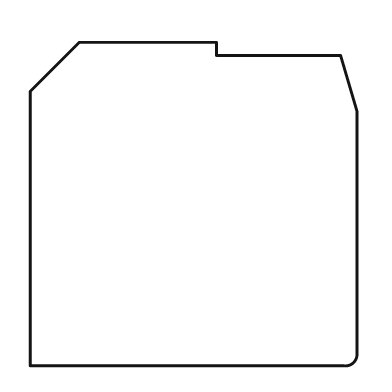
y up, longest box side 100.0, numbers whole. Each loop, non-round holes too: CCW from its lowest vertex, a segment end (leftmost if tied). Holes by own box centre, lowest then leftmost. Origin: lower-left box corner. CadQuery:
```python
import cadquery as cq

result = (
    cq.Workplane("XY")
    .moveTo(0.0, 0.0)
    .lineTo(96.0, 0.0)
    .threePointArc((99.0, 1.0), (100.0, 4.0))
    .lineTo(100.0, 78.0)
    .lineTo(95.0, 95.0)
    .lineTo(57.0, 95.0)
    .lineTo(57.0, 99.0)
    .lineTo(15.0, 99.0)
    .lineTo(0.0, 84.0)
    .close()
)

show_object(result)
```